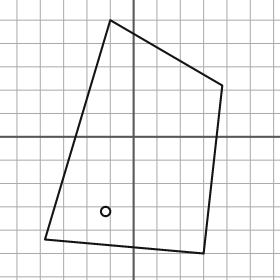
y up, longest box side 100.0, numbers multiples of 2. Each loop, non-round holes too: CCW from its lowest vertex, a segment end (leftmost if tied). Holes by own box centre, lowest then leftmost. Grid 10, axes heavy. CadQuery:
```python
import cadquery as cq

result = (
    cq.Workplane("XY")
    .moveTo(30.0, -50.0)
    .lineTo(38.0, 22.0)
    .lineTo(-10.0, 50.0)
    .lineTo(-38.0, -44.0)
    .close()
    .moveTo(-12.0, -32.0)
    .circle(2.0)
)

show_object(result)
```